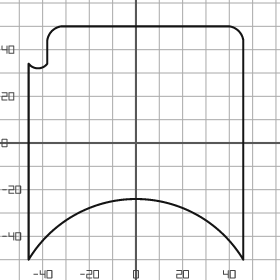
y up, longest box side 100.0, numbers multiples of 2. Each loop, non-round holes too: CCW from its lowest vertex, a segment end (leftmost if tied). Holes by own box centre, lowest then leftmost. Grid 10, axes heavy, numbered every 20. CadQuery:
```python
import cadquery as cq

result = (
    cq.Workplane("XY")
    .moveTo(-46.0, -50.0)
    .threePointArc((0.0, -24.0), (46.0, -50.0))
    .lineTo(46.0, 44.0)
    .threePointArc((44.0, 48.0), (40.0, 50.0))
    .lineTo(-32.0, 50.0)
    .threePointArc((-36.0, 48.0), (-38.0, 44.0))
    .lineTo(-38.0, 34.0)
    .threePointArc((-42.0, 32.0), (-46.0, 34.0))
    .close()
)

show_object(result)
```